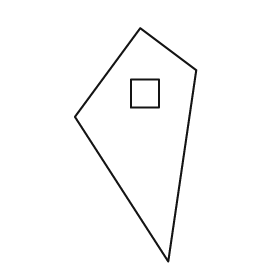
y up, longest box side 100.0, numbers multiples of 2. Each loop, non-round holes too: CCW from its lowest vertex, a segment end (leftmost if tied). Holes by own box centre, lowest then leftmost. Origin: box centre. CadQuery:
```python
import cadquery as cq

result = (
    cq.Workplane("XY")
    .moveTo(14.0, -50.0)
    .lineTo(26.0, 32.0)
    .lineTo(2.0, 50.0)
    .lineTo(-26.0, 12.0)
    .close()
    .moveTo(-2.0, 16.0)
    .lineTo(10.0, 16.0)
    .lineTo(10.0, 28.0)
    .lineTo(-2.0, 28.0)
    .close()
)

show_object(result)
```